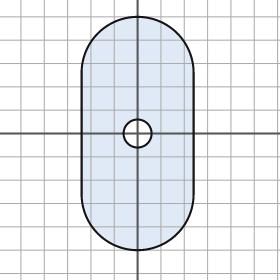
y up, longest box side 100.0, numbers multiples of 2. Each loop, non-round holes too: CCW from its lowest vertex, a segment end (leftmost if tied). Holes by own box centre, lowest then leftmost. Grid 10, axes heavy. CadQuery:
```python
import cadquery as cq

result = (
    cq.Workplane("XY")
    .moveTo(-24.0, -26.0)
    .threePointArc((0.0, -50.0), (24.0, -26.0))
    .lineTo(24.0, 26.0)
    .threePointArc((0.0, 50.0), (-24.0, 26.0))
    .close()
    .moveTo(0.0, 0.0)
    .circle(6.0)
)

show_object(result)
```